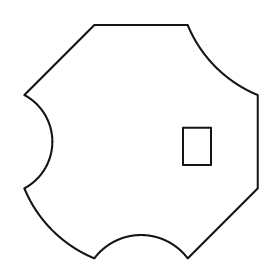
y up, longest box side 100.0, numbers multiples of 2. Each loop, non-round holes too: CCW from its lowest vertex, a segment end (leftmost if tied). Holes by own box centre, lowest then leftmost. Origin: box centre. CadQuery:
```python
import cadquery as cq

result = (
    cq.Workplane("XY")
    .moveTo(-20.0, -50.0)
    .threePointArc((0.0, -40.0), (20.0, -50.0))
    .lineTo(50.0, -20.0)
    .lineTo(50.0, 20.0)
    .threePointArc((32.0, 32.0), (20.0, 50.0))
    .lineTo(-20.0, 50.0)
    .lineTo(-50.0, 20.0)
    .threePointArc((-38.0, 0.0), (-50.0, -20.0))
    .threePointArc((-38.0, -38.0), (-20.0, -50.0))
    .close()
    .moveTo(18.0, -10.0)
    .lineTo(30.0, -10.0)
    .lineTo(30.0, 6.0)
    .lineTo(18.0, 6.0)
    .close()
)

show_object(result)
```